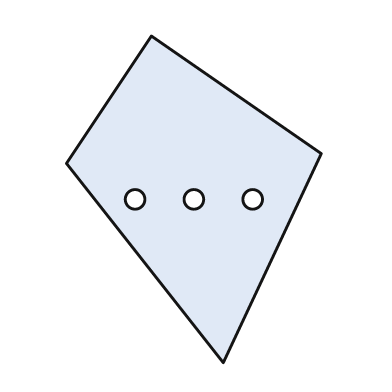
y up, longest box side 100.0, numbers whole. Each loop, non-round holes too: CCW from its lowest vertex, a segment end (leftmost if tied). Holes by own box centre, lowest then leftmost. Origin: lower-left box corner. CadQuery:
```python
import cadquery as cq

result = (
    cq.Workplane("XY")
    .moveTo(48.0, 0.0)
    .lineTo(78.0, 64.0)
    .lineTo(26.0, 100.0)
    .lineTo(0.0, 61.0)
    .close()
    .moveTo(21.0, 50.0)
    .circle(3.0)
    .moveTo(39.0, 50.0)
    .circle(3.0)
    .moveTo(57.0, 50.0)
    .circle(3.0)
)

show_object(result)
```